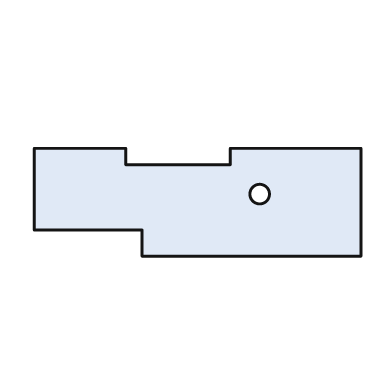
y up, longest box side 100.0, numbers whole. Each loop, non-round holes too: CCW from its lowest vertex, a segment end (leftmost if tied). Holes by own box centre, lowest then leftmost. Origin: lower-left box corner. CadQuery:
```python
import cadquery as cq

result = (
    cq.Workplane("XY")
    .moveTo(33.0, 0.0)
    .lineTo(100.0, 0.0)
    .lineTo(100.0, 33.0)
    .lineTo(60.0, 33.0)
    .lineTo(60.0, 28.0)
    .lineTo(28.0, 28.0)
    .lineTo(28.0, 33.0)
    .lineTo(0.0, 33.0)
    .lineTo(0.0, 8.0)
    .lineTo(33.0, 8.0)
    .close()
    .moveTo(69.0, 19.0)
    .circle(3.0)
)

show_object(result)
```